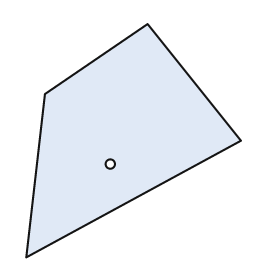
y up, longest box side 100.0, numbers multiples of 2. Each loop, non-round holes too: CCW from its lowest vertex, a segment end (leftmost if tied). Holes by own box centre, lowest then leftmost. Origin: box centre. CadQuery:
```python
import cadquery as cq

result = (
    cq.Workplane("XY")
    .moveTo(-46.0, -50.0)
    .lineTo(46.0, 0.0)
    .lineTo(6.0, 50.0)
    .lineTo(-38.0, 20.0)
    .close()
    .moveTo(-10.0, -10.0)
    .circle(2.0)
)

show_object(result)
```